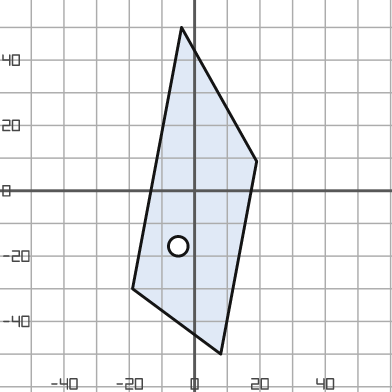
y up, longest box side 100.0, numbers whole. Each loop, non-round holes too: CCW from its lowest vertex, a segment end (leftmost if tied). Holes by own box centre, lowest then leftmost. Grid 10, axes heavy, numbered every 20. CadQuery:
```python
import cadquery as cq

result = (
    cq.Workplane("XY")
    .moveTo(8.0, -50.0)
    .lineTo(19.0, 9.0)
    .lineTo(-4.0, 50.0)
    .lineTo(-19.0, -30.0)
    .close()
    .moveTo(-5.0, -17.0)
    .circle(3.0)
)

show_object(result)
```